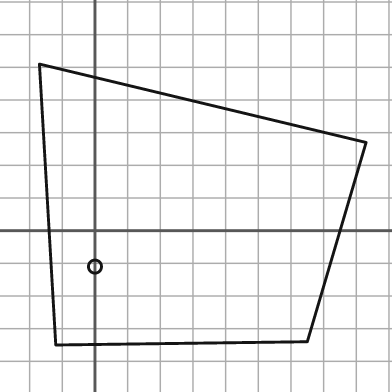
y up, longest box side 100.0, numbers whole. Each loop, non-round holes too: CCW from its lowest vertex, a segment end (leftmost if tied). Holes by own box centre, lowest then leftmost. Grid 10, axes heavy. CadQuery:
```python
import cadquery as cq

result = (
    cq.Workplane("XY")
    .moveTo(-12.0, -35.0)
    .lineTo(65.0, -34.0)
    .lineTo(83.0, 27.0)
    .lineTo(-17.0, 51.0)
    .close()
    .moveTo(0.0, -11.0)
    .circle(2.0)
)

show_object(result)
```